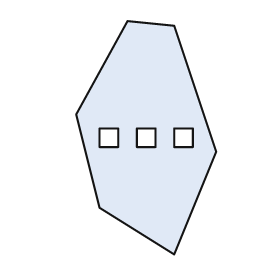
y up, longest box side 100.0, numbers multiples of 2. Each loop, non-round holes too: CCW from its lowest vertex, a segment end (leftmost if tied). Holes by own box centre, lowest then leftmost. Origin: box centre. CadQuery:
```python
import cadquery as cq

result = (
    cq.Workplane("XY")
    .moveTo(12.0, -50.0)
    .lineTo(30.0, -6.0)
    .lineTo(12.0, 48.0)
    .lineTo(-8.0, 50.0)
    .lineTo(-30.0, 10.0)
    .lineTo(-20.0, -30.0)
    .close()
    .moveTo(-20.0, -4.0)
    .lineTo(-12.0, -4.0)
    .lineTo(-12.0, 4.0)
    .lineTo(-20.0, 4.0)
    .close()
    .moveTo(-4.0, -4.0)
    .lineTo(4.0, -4.0)
    .lineTo(4.0, 4.0)
    .lineTo(-4.0, 4.0)
    .close()
    .moveTo(12.0, -4.0)
    .lineTo(20.0, -4.0)
    .lineTo(20.0, 4.0)
    .lineTo(12.0, 4.0)
    .close()
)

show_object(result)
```